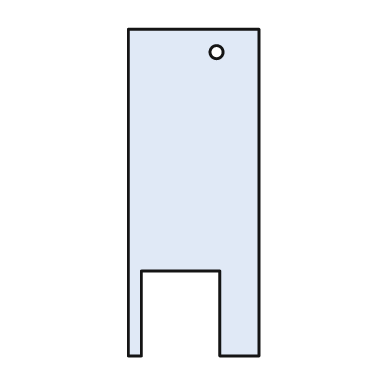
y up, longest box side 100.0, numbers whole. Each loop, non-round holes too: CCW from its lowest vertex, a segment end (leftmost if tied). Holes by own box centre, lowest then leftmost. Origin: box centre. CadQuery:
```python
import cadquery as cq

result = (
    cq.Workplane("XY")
    .moveTo(-20.0, -50.0)
    .lineTo(-16.0, -50.0)
    .lineTo(-16.0, -24.0)
    .lineTo(8.0, -24.0)
    .lineTo(8.0, -50.0)
    .lineTo(20.0, -50.0)
    .lineTo(20.0, 50.0)
    .lineTo(-20.0, 50.0)
    .close()
    .moveTo(7.0, 43.0)
    .circle(2.0)
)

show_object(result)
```